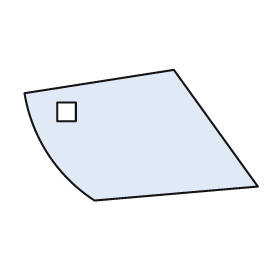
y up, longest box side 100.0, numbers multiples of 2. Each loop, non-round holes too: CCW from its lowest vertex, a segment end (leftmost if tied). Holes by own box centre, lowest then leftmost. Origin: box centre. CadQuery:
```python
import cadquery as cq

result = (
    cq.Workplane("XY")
    .moveTo(-20.0, -28.0)
    .lineTo(50.0, -22.0)
    .lineTo(14.0, 28.0)
    .lineTo(-50.0, 18.0)
    .threePointArc((-40.0, -8.0), (-20.0, -28.0))
    .close()
    .moveTo(-36.0, 6.0)
    .lineTo(-28.0, 6.0)
    .lineTo(-28.0, 14.0)
    .lineTo(-36.0, 14.0)
    .close()
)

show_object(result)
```